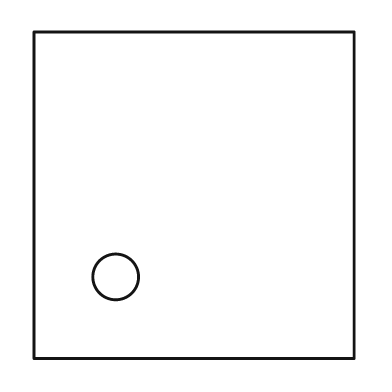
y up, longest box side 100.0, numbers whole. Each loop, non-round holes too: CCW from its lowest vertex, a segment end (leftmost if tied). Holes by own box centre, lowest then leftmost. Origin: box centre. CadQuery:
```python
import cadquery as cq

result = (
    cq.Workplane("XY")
    .moveTo(-49.0, -50.0)
    .lineTo(49.0, -50.0)
    .lineTo(49.0, 50.0)
    .lineTo(-49.0, 50.0)
    .close()
    .moveTo(-24.0, -25.0)
    .circle(7.0)
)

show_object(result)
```